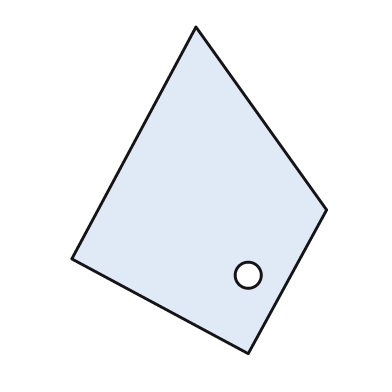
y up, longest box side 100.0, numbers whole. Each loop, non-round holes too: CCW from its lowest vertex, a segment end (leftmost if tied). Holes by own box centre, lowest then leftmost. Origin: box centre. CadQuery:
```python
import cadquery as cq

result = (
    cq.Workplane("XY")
    .moveTo(15.0, -50.0)
    .lineTo(39.0, -6.0)
    .lineTo(-1.0, 50.0)
    .lineTo(-39.0, -21.0)
    .close()
    .moveTo(15.0, -26.0)
    .circle(4.0)
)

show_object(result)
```